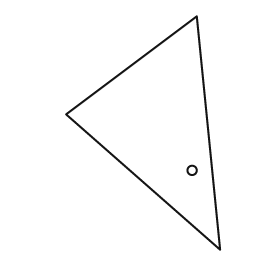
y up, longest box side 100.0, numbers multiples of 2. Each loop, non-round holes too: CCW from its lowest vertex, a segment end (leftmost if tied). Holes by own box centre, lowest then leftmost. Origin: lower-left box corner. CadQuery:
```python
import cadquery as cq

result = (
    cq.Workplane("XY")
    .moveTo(66.0, 0.0)
    .lineTo(56.0, 100.0)
    .lineTo(0.0, 58.0)
    .close()
    .moveTo(54.0, 34.0)
    .circle(2.0)
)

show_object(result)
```